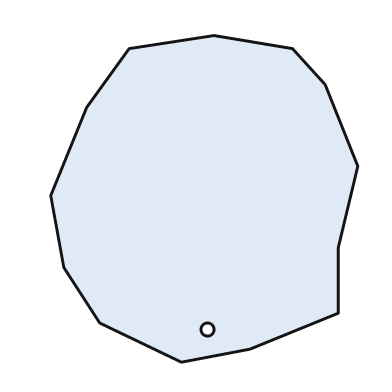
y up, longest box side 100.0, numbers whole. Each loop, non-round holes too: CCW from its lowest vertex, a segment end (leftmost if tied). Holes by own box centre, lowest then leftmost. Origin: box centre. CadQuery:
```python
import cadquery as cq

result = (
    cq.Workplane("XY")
    .moveTo(-7.0, -50.0)
    .lineTo(14.0, -46.0)
    .lineTo(41.0, -35.0)
    .lineTo(41.0, -15.0)
    .lineTo(47.0, 10.0)
    .lineTo(37.0, 35.0)
    .lineTo(27.0, 46.0)
    .lineTo(3.0, 50.0)
    .lineTo(-23.0, 46.0)
    .lineTo(-36.0, 28.0)
    .lineTo(-47.0, 1.0)
    .lineTo(-43.0, -21.0)
    .lineTo(-32.0, -38.0)
    .close()
    .moveTo(1.0, -40.0)
    .circle(2.0)
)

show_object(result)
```